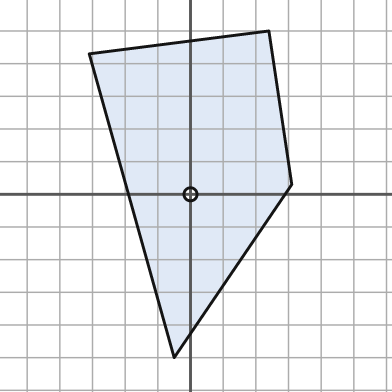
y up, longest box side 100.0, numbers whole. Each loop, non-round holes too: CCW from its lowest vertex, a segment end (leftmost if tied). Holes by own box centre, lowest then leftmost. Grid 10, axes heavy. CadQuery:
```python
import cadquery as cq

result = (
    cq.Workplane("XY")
    .moveTo(-5.0, -50.0)
    .lineTo(31.0, 3.0)
    .lineTo(24.0, 50.0)
    .lineTo(-31.0, 43.0)
    .close()
    .moveTo(0.0, 0.0)
    .circle(2.0)
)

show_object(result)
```